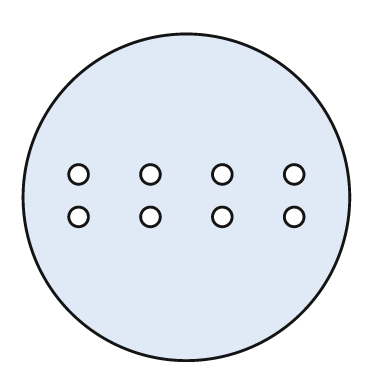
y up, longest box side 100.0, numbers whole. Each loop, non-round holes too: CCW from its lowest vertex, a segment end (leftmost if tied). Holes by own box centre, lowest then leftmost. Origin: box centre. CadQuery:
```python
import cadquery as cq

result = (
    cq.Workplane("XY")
    .moveTo(0.0, 0.0)
    .circle(50.0)
    .moveTo(-33.0, -6.0)
    .circle(3.0)
    .moveTo(-11.0, -6.0)
    .circle(3.0)
    .moveTo(11.0, -6.0)
    .circle(3.0)
    .moveTo(33.0, -6.0)
    .circle(3.0)
    .moveTo(-33.0, 7.0)
    .circle(3.0)
    .moveTo(-11.0, 7.0)
    .circle(3.0)
    .moveTo(11.0, 7.0)
    .circle(3.0)
    .moveTo(33.0, 7.0)
    .circle(3.0)
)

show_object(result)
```